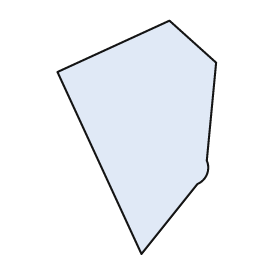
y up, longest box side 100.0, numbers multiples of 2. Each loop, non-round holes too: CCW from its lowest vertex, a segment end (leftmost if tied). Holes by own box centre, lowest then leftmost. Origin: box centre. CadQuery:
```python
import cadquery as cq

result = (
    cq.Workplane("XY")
    .moveTo(2.0, -50.0)
    .lineTo(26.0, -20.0)
    .threePointArc((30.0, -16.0), (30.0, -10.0))
    .lineTo(34.0, 32.0)
    .lineTo(14.0, 50.0)
    .lineTo(-34.0, 28.0)
    .close()
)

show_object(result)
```